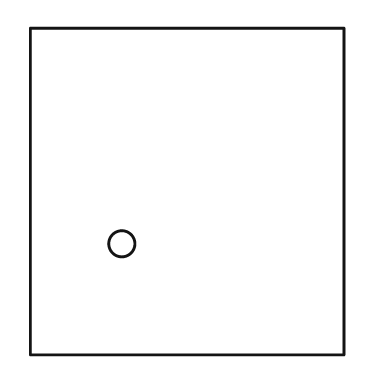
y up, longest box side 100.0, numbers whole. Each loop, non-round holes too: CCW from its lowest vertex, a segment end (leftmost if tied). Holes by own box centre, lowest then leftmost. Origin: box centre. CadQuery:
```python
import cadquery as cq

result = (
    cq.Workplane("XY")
    .moveTo(-48.0, -50.0)
    .lineTo(48.0, -50.0)
    .lineTo(48.0, 50.0)
    .lineTo(-48.0, 50.0)
    .close()
    .moveTo(-20.0, -16.0)
    .circle(4.0)
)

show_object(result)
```